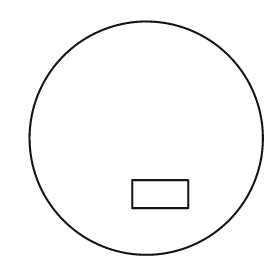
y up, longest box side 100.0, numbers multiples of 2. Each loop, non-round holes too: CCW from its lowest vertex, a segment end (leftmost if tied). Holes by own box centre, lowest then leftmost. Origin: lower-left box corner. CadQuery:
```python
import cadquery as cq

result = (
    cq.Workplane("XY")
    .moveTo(50.0, 50.0)
    .circle(50.0)
    .moveTo(44.0, 20.0)
    .lineTo(68.0, 20.0)
    .lineTo(68.0, 32.0)
    .lineTo(44.0, 32.0)
    .close()
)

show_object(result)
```